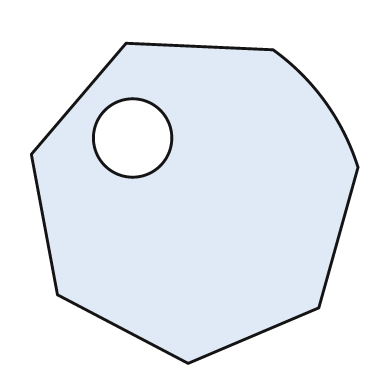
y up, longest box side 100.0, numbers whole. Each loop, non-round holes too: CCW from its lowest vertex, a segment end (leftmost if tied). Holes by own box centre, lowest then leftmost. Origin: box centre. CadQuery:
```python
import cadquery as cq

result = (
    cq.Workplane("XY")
    .moveTo(-2.0, -49.0)
    .lineTo(38.0, -32.0)
    .lineTo(50.0, 11.0)
    .threePointArc((40.0, 31.0), (24.0, 47.0))
    .lineTo(-21.0, 49.0)
    .lineTo(-50.0, 15.0)
    .lineTo(-42.0, -28.0)
    .close()
    .moveTo(-19.0, 20.0)
    .circle(12.0)
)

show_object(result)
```